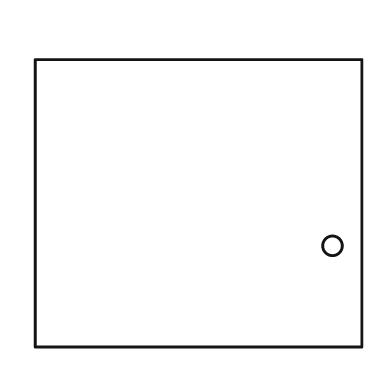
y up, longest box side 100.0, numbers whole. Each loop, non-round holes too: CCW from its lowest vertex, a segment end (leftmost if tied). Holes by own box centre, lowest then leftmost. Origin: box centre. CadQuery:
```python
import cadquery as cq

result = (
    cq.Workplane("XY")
    .moveTo(-50.0, -44.0)
    .lineTo(50.0, -44.0)
    .lineTo(50.0, 44.0)
    .lineTo(-50.0, 44.0)
    .close()
    .moveTo(41.0, -13.0)
    .circle(3.0)
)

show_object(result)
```